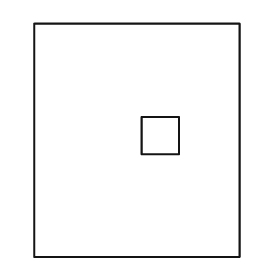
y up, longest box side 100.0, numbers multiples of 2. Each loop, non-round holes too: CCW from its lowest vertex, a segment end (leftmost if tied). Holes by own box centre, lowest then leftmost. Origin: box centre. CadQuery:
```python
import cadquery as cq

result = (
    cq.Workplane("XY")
    .moveTo(-44.0, -50.0)
    .lineTo(44.0, -50.0)
    .lineTo(44.0, 50.0)
    .lineTo(-44.0, 50.0)
    .close()
    .moveTo(2.0, -6.0)
    .lineTo(18.0, -6.0)
    .lineTo(18.0, 10.0)
    .lineTo(2.0, 10.0)
    .close()
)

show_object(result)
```